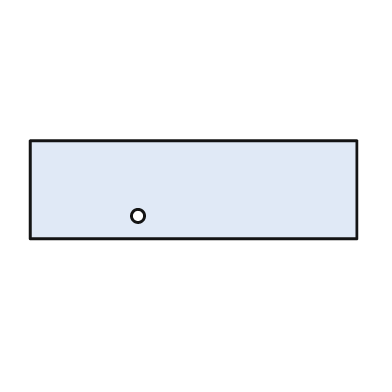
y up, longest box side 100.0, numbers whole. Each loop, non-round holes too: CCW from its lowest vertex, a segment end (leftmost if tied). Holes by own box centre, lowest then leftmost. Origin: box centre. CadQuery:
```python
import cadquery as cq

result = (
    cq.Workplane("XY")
    .moveTo(-50.0, -15.0)
    .lineTo(50.0, -15.0)
    .lineTo(50.0, 15.0)
    .lineTo(-50.0, 15.0)
    .close()
    .moveTo(-17.0, -8.0)
    .circle(2.0)
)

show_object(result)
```